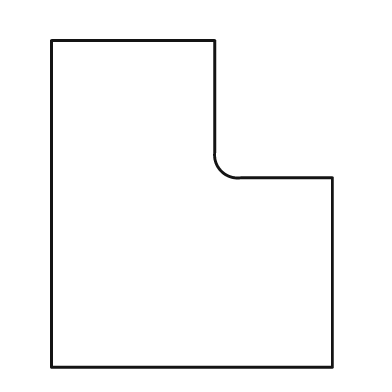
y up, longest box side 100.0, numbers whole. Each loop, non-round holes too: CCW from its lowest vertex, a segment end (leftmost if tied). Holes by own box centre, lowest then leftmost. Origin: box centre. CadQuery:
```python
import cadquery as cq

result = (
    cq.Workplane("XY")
    .moveTo(-43.0, -50.0)
    .lineTo(43.0, -50.0)
    .lineTo(43.0, 8.0)
    .lineTo(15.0, 8.0)
    .threePointArc((9.0, 10.0), (7.0, 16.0))
    .lineTo(7.0, 50.0)
    .lineTo(-43.0, 50.0)
    .close()
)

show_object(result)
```